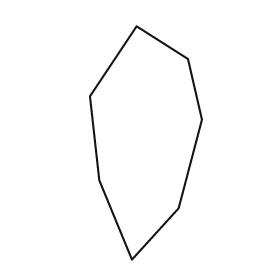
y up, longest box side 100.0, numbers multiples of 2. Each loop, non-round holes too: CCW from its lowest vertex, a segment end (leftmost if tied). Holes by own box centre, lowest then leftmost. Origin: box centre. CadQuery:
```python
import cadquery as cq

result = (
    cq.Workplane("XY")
    .moveTo(-6.0, -50.0)
    .lineTo(14.0, -28.0)
    .lineTo(24.0, 10.0)
    .lineTo(18.0, 36.0)
    .lineTo(-4.0, 50.0)
    .lineTo(-24.0, 20.0)
    .lineTo(-20.0, -16.0)
    .close()
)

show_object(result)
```